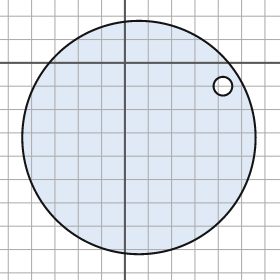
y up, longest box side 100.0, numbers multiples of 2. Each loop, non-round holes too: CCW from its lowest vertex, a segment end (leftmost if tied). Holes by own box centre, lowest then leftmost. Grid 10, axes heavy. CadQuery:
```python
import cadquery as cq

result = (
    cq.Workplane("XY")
    .moveTo(6.0, -32.0)
    .circle(50.0)
    .moveTo(42.0, -10.0)
    .circle(4.0)
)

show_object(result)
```